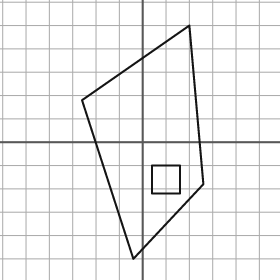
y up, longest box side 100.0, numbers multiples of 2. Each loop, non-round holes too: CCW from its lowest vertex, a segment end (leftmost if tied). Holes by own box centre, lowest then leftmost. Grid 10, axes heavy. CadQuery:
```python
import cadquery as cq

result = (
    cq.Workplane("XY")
    .moveTo(-4.0, -50.0)
    .lineTo(26.0, -18.0)
    .lineTo(20.0, 50.0)
    .lineTo(-26.0, 18.0)
    .close()
    .moveTo(4.0, -22.0)
    .lineTo(16.0, -22.0)
    .lineTo(16.0, -10.0)
    .lineTo(4.0, -10.0)
    .close()
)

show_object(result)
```